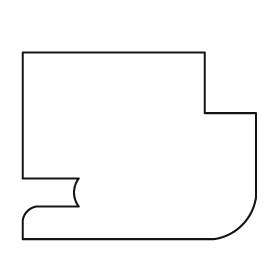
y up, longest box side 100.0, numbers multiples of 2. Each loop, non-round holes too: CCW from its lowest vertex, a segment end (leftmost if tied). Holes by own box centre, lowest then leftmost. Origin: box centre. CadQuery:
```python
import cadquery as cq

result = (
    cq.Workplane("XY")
    .moveTo(-50.0, -40.0)
    .lineTo(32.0, -40.0)
    .threePointArc((44.0, -34.0), (50.0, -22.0))
    .lineTo(50.0, 14.0)
    .lineTo(28.0, 14.0)
    .lineTo(28.0, 40.0)
    .lineTo(-50.0, 40.0)
    .lineTo(-50.0, -14.0)
    .lineTo(-26.0, -14.0)
    .threePointArc((-28.0, -20.0), (-26.0, -26.0))
    .lineTo(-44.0, -26.0)
    .threePointArc((-48.0, -28.0), (-50.0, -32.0))
    .close()
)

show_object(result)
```